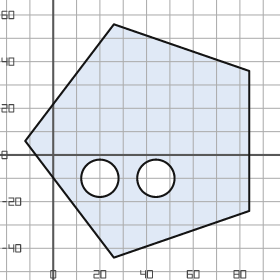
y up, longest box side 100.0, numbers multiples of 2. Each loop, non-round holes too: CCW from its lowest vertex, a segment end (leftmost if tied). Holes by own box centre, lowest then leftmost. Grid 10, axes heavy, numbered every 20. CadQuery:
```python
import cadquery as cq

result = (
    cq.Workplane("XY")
    .moveTo(26.0, -44.0)
    .lineTo(84.0, -24.0)
    .lineTo(84.0, 36.0)
    .lineTo(26.0, 56.0)
    .lineTo(-12.0, 6.0)
    .close()
    .moveTo(20.0, -10.0)
    .circle(8.0)
    .moveTo(44.0, -10.0)
    .circle(8.0)
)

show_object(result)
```